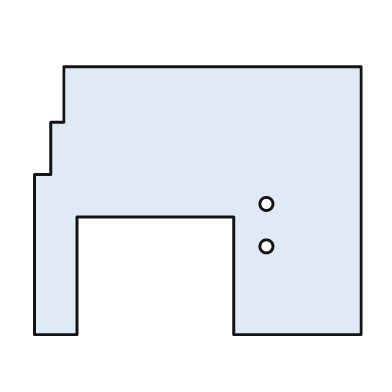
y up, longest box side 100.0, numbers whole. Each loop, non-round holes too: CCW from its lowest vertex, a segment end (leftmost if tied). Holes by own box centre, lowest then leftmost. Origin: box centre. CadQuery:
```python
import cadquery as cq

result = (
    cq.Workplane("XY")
    .moveTo(-50.0, -41.0)
    .lineTo(-37.0, -41.0)
    .lineTo(-37.0, -5.0)
    .lineTo(11.0, -5.0)
    .lineTo(11.0, -41.0)
    .lineTo(50.0, -41.0)
    .lineTo(50.0, 41.0)
    .lineTo(-41.0, 41.0)
    .lineTo(-41.0, 24.0)
    .lineTo(-45.0, 24.0)
    .lineTo(-45.0, 8.0)
    .lineTo(-50.0, 8.0)
    .close()
    .moveTo(21.0, -14.0)
    .circle(2.0)
    .moveTo(21.0, -1.0)
    .circle(2.0)
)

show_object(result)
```